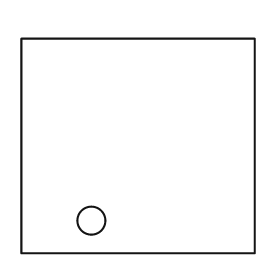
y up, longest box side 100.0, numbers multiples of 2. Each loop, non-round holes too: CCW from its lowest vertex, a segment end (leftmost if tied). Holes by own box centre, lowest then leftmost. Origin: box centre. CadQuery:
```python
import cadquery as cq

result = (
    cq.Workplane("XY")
    .moveTo(-50.0, -46.0)
    .lineTo(50.0, -46.0)
    .lineTo(50.0, 46.0)
    .lineTo(-50.0, 46.0)
    .close()
    .moveTo(-20.0, -32.0)
    .circle(6.0)
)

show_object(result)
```